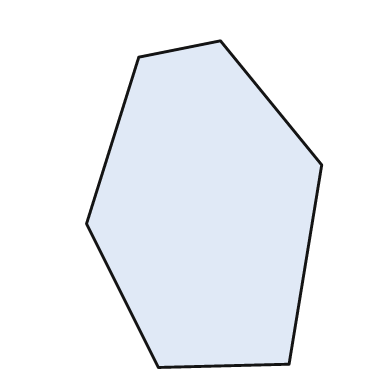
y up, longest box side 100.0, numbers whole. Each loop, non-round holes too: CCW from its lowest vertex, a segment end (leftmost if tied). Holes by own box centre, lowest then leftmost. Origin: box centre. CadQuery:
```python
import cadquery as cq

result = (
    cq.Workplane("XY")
    .moveTo(-14.0, -50.0)
    .lineTo(26.0, -49.0)
    .lineTo(36.0, 12.0)
    .lineTo(5.0, 50.0)
    .lineTo(-20.0, 45.0)
    .lineTo(-36.0, -6.0)
    .close()
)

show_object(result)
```